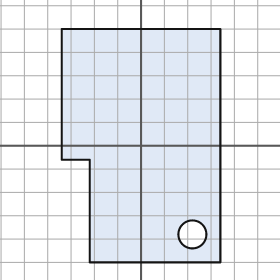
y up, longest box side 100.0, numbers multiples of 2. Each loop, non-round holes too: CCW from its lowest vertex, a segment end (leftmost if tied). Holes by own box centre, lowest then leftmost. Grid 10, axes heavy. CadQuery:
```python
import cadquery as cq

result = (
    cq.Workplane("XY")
    .moveTo(-22.0, -50.0)
    .lineTo(34.0, -50.0)
    .lineTo(34.0, 50.0)
    .lineTo(-34.0, 50.0)
    .lineTo(-34.0, -6.0)
    .lineTo(-22.0, -6.0)
    .close()
    .moveTo(22.0, -38.0)
    .circle(6.0)
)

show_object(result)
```